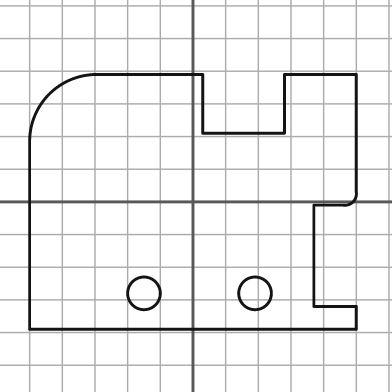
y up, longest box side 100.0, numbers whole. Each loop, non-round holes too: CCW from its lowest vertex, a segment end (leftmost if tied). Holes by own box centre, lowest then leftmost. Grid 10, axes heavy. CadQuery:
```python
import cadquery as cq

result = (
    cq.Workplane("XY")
    .moveTo(-50.0, -39.0)
    .lineTo(50.0, -39.0)
    .lineTo(50.0, -32.0)
    .lineTo(37.0, -32.0)
    .lineTo(37.0, -1.0)
    .lineTo(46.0, -1.0)
    .threePointArc((49.0, 0.0), (50.0, 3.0))
    .lineTo(50.0, 39.0)
    .lineTo(28.0, 39.0)
    .lineTo(28.0, 21.0)
    .lineTo(3.0, 21.0)
    .lineTo(3.0, 39.0)
    .lineTo(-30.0, 39.0)
    .threePointArc((-44.0, 33.0), (-50.0, 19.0))
    .close()
    .moveTo(-15.0, -28.0)
    .circle(5.0)
    .moveTo(19.0, -28.0)
    .circle(5.0)
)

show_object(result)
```